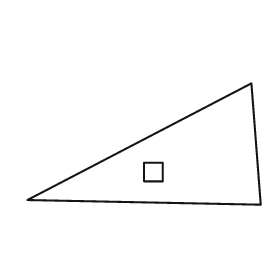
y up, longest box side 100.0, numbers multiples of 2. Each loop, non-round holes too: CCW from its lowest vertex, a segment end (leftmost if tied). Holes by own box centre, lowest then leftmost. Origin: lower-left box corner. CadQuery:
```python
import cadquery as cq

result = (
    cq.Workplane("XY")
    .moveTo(100.0, 0.0)
    .lineTo(96.0, 52.0)
    .lineTo(0.0, 2.0)
    .close()
    .moveTo(50.0, 10.0)
    .lineTo(58.0, 10.0)
    .lineTo(58.0, 18.0)
    .lineTo(50.0, 18.0)
    .close()
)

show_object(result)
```